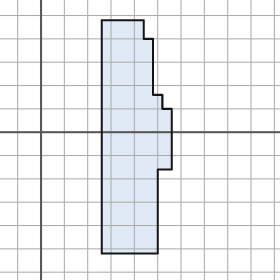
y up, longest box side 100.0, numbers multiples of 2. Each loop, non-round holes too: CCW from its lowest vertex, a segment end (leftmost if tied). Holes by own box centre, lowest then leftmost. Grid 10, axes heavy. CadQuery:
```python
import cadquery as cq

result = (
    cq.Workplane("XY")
    .moveTo(26.0, -52.0)
    .lineTo(50.0, -52.0)
    .lineTo(50.0, -16.0)
    .lineTo(56.0, -16.0)
    .lineTo(56.0, 10.0)
    .lineTo(52.0, 10.0)
    .lineTo(52.0, 16.0)
    .lineTo(48.0, 16.0)
    .lineTo(48.0, 40.0)
    .lineTo(44.0, 40.0)
    .lineTo(44.0, 48.0)
    .lineTo(26.0, 48.0)
    .close()
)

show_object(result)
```